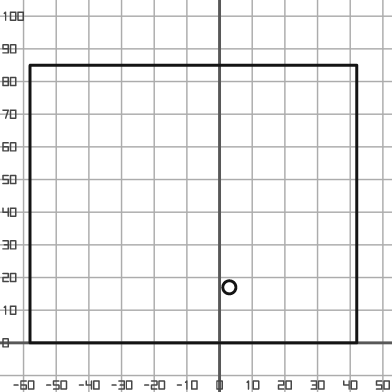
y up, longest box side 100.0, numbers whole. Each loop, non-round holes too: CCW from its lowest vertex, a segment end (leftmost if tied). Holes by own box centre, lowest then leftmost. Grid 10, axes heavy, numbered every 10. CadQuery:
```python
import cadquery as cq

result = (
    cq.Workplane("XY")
    .moveTo(-58.0, 0.0)
    .lineTo(42.0, 0.0)
    .lineTo(42.0, 85.0)
    .lineTo(-58.0, 85.0)
    .close()
    .moveTo(3.0, 17.0)
    .circle(2.0)
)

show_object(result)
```